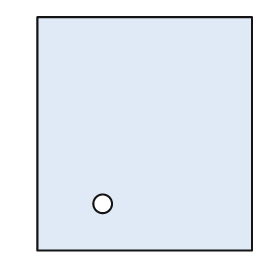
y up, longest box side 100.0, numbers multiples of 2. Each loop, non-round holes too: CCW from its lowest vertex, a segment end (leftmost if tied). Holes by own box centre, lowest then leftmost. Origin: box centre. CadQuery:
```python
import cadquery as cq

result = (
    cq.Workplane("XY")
    .moveTo(-46.0, -50.0)
    .lineTo(46.0, -50.0)
    .lineTo(46.0, 50.0)
    .lineTo(-46.0, 50.0)
    .close()
    .moveTo(-18.0, -30.0)
    .circle(4.0)
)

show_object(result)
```